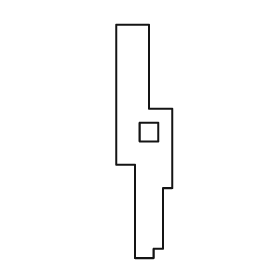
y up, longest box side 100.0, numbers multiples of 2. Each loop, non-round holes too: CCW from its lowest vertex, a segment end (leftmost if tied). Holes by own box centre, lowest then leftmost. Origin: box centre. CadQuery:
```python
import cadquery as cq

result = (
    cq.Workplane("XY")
    .moveTo(-4.0, -50.0)
    .lineTo(4.0, -50.0)
    .lineTo(4.0, -46.0)
    .lineTo(8.0, -46.0)
    .lineTo(8.0, -20.0)
    .lineTo(12.0, -20.0)
    .lineTo(12.0, 14.0)
    .lineTo(2.0, 14.0)
    .lineTo(2.0, 50.0)
    .lineTo(-12.0, 50.0)
    .lineTo(-12.0, -10.0)
    .lineTo(-4.0, -10.0)
    .close()
    .moveTo(-2.0, 0.0)
    .lineTo(6.0, 0.0)
    .lineTo(6.0, 8.0)
    .lineTo(-2.0, 8.0)
    .close()
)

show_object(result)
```